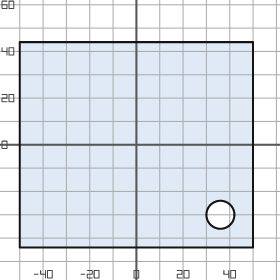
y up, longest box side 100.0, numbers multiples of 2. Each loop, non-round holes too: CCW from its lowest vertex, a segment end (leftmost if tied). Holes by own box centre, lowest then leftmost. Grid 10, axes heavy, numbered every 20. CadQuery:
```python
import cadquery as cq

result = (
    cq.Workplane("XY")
    .moveTo(-50.0, -44.0)
    .lineTo(50.0, -44.0)
    .lineTo(50.0, 44.0)
    .lineTo(-50.0, 44.0)
    .close()
    .moveTo(36.0, -30.0)
    .circle(6.0)
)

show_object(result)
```